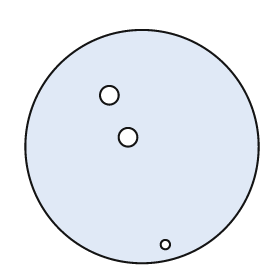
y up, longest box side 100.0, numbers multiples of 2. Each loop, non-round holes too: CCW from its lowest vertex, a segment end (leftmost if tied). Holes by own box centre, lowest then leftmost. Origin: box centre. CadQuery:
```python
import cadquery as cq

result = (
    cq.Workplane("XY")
    .moveTo(0.0, 0.0)
    .circle(50.0)
    .moveTo(10.0, -42.0)
    .circle(2.0)
    .moveTo(-6.0, 4.0)
    .circle(4.0)
    .moveTo(-14.0, 22.0)
    .circle(4.0)
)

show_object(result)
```